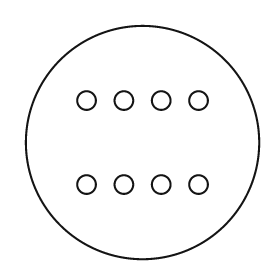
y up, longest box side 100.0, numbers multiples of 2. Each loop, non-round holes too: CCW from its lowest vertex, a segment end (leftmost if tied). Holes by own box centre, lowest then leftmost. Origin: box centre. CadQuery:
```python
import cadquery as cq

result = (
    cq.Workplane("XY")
    .moveTo(0.0, 0.0)
    .circle(50.0)
    .moveTo(-24.0, -18.0)
    .circle(4.0)
    .moveTo(-8.0, -18.0)
    .circle(4.0)
    .moveTo(8.0, -18.0)
    .circle(4.0)
    .moveTo(24.0, -18.0)
    .circle(4.0)
    .moveTo(-24.0, 18.0)
    .circle(4.0)
    .moveTo(-8.0, 18.0)
    .circle(4.0)
    .moveTo(8.0, 18.0)
    .circle(4.0)
    .moveTo(24.0, 18.0)
    .circle(4.0)
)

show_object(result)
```